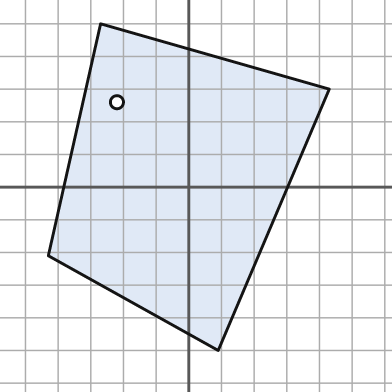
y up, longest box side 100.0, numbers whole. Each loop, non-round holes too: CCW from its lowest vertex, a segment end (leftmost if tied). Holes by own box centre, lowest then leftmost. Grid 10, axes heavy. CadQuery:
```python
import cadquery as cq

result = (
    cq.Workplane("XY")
    .moveTo(9.0, -50.0)
    .lineTo(43.0, 30.0)
    .lineTo(-27.0, 50.0)
    .lineTo(-43.0, -21.0)
    .close()
    .moveTo(-22.0, 26.0)
    .circle(2.0)
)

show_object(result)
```